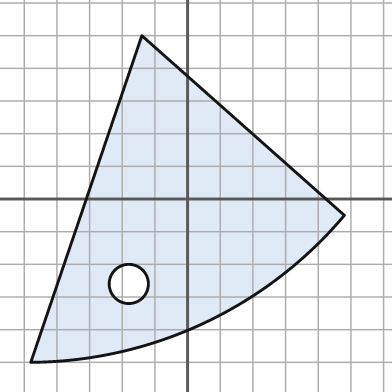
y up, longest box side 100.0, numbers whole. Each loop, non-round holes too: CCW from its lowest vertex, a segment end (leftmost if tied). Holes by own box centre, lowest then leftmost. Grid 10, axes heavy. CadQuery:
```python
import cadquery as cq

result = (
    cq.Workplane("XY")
    .moveTo(-48.0, -50.0)
    .threePointArc((5.0, -38.0), (48.0, -5.0))
    .lineTo(-14.0, 50.0)
    .close()
    .moveTo(-18.0, -26.0)
    .circle(6.0)
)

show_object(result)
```